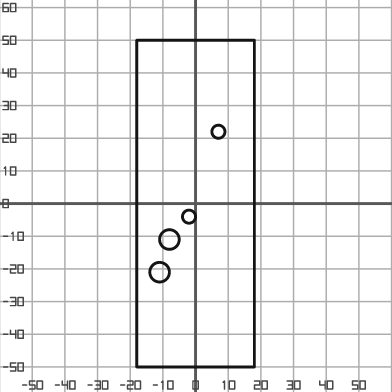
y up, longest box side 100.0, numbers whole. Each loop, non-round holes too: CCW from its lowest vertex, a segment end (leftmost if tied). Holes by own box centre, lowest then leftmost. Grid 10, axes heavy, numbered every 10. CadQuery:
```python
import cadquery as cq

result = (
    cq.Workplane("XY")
    .moveTo(-18.0, -50.0)
    .lineTo(18.0, -50.0)
    .lineTo(18.0, 50.0)
    .lineTo(-18.0, 50.0)
    .close()
    .moveTo(-11.0, -21.0)
    .circle(3.0)
    .moveTo(-8.0, -11.0)
    .circle(3.0)
    .moveTo(-2.0, -4.0)
    .circle(2.0)
    .moveTo(7.0, 22.0)
    .circle(2.0)
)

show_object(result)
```